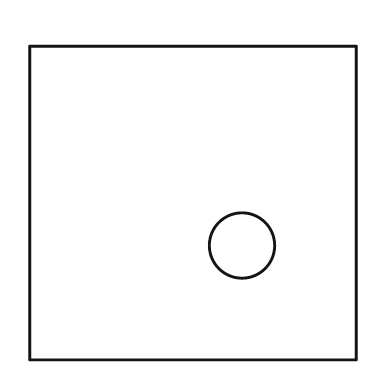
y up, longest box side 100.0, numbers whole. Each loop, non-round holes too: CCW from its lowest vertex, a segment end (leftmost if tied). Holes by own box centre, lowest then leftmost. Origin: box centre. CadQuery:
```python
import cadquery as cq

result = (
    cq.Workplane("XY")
    .moveTo(-50.0, -48.0)
    .lineTo(50.0, -48.0)
    .lineTo(50.0, 48.0)
    .lineTo(-50.0, 48.0)
    .close()
    .moveTo(15.0, -13.0)
    .circle(10.0)
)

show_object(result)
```